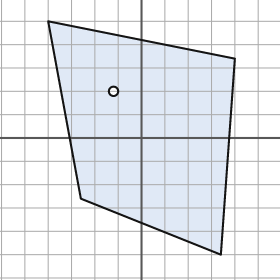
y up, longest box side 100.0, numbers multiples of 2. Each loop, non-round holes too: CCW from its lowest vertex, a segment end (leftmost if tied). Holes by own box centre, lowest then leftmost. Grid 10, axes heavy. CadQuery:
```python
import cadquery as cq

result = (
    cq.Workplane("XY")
    .moveTo(34.0, -50.0)
    .lineTo(40.0, 34.0)
    .lineTo(-40.0, 50.0)
    .lineTo(-26.0, -26.0)
    .close()
    .moveTo(-12.0, 20.0)
    .circle(2.0)
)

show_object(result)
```